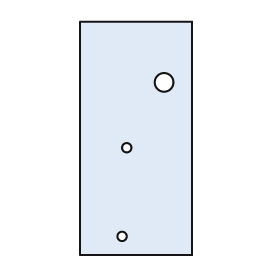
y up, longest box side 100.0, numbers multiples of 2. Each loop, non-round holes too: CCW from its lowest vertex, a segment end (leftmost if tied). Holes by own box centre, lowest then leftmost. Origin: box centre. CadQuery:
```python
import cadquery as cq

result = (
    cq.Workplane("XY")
    .moveTo(-24.0, -50.0)
    .lineTo(24.0, -50.0)
    .lineTo(24.0, 50.0)
    .lineTo(-24.0, 50.0)
    .close()
    .moveTo(-6.0, -42.0)
    .circle(2.0)
    .moveTo(-4.0, -4.0)
    .circle(2.0)
    .moveTo(12.0, 24.0)
    .circle(4.0)
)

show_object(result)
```